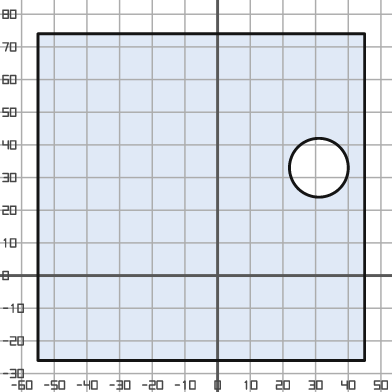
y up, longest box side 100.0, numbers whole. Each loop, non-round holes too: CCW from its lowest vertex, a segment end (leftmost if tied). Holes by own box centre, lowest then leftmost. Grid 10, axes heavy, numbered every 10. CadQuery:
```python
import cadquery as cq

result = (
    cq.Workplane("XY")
    .moveTo(-55.0, -26.0)
    .lineTo(45.0, -26.0)
    .lineTo(45.0, 74.0)
    .lineTo(-55.0, 74.0)
    .close()
    .moveTo(31.0, 33.0)
    .circle(9.0)
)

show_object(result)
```